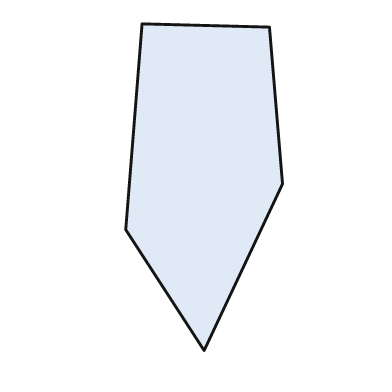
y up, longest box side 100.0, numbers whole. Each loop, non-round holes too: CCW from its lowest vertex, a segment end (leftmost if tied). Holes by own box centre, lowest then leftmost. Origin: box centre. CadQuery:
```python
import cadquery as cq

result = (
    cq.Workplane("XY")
    .moveTo(0.0, -50.0)
    .lineTo(24.0, 1.0)
    .lineTo(20.0, 49.0)
    .lineTo(-19.0, 50.0)
    .lineTo(-24.0, -13.0)
    .close()
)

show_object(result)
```